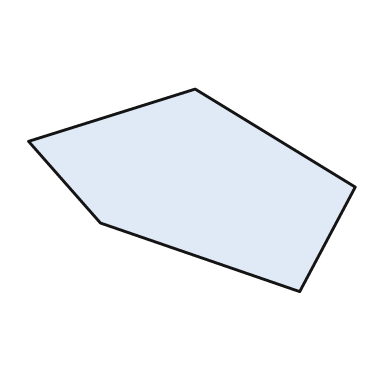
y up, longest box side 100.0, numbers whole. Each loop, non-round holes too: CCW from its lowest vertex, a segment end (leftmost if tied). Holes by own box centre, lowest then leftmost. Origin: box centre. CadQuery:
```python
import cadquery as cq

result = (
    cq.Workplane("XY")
    .moveTo(33.0, -31.0)
    .lineTo(50.0, 1.0)
    .lineTo(1.0, 31.0)
    .lineTo(-50.0, 15.0)
    .lineTo(-28.0, -10.0)
    .close()
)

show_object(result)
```